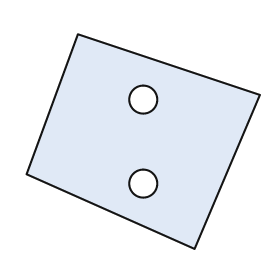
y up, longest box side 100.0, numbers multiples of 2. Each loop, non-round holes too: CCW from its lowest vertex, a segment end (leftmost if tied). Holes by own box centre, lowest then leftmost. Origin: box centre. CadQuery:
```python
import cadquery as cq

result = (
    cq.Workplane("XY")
    .moveTo(22.0, -46.0)
    .lineTo(50.0, 20.0)
    .lineTo(-28.0, 46.0)
    .lineTo(-50.0, -14.0)
    .close()
    .moveTo(0.0, -18.0)
    .circle(6.0)
    .moveTo(0.0, 18.0)
    .circle(6.0)
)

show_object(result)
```